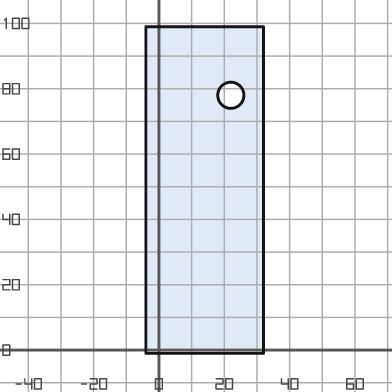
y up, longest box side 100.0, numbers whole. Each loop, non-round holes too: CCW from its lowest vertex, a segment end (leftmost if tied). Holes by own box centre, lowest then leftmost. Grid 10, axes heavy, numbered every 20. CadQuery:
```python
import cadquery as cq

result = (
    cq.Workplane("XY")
    .moveTo(-4.0, -1.0)
    .lineTo(32.0, -1.0)
    .lineTo(32.0, 99.0)
    .lineTo(-4.0, 99.0)
    .close()
    .moveTo(22.0, 78.0)
    .circle(4.0)
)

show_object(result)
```